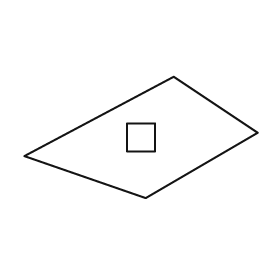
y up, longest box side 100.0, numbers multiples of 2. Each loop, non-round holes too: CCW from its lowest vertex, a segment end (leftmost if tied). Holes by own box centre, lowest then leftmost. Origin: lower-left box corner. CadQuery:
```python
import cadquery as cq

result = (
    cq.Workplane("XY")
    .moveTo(52.0, 0.0)
    .lineTo(100.0, 28.0)
    .lineTo(64.0, 52.0)
    .lineTo(0.0, 18.0)
    .close()
    .moveTo(44.0, 20.0)
    .lineTo(56.0, 20.0)
    .lineTo(56.0, 32.0)
    .lineTo(44.0, 32.0)
    .close()
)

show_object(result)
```